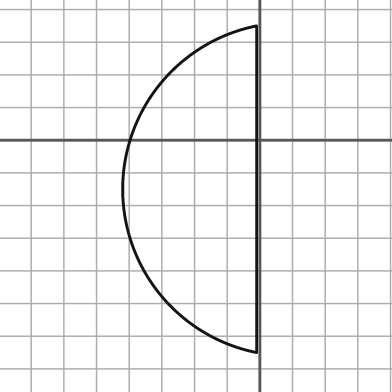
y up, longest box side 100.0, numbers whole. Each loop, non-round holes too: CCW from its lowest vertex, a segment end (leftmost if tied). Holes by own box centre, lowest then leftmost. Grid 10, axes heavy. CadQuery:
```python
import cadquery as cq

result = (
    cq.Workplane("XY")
    .moveTo(-1.0, -65.0)
    .lineTo(-1.0, 35.0)
    .threePointArc((-42.0, -15.0), (-1.0, -65.0))
    .close()
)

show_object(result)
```